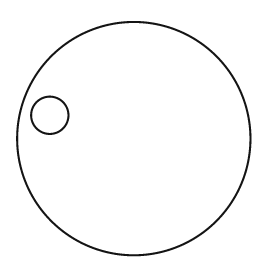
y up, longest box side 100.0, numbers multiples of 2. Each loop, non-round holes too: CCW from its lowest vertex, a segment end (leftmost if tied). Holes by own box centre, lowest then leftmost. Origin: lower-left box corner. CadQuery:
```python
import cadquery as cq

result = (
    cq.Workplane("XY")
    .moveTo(50.0, 50.0)
    .circle(50.0)
    .moveTo(14.0, 60.0)
    .circle(8.0)
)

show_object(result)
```